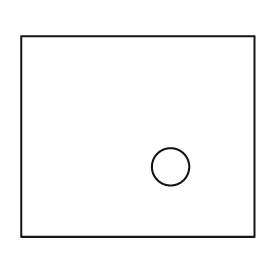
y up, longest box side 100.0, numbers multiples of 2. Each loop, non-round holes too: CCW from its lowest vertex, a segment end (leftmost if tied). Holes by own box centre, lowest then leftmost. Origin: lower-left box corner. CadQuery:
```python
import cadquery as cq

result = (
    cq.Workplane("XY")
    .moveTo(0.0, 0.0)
    .lineTo(100.0, 0.0)
    .lineTo(100.0, 86.0)
    .lineTo(0.0, 86.0)
    .close()
    .moveTo(64.0, 30.0)
    .circle(8.0)
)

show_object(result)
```